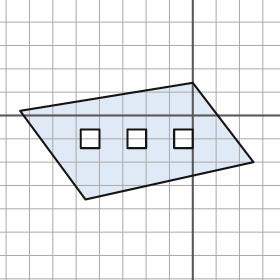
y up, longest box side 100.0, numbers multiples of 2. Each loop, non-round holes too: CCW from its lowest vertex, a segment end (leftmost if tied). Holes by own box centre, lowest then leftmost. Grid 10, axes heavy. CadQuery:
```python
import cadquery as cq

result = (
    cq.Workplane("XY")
    .moveTo(-46.0, -36.0)
    .lineTo(26.0, -20.0)
    .lineTo(0.0, 14.0)
    .lineTo(-74.0, 2.0)
    .close()
    .moveTo(-48.0, -14.0)
    .lineTo(-40.0, -14.0)
    .lineTo(-40.0, -6.0)
    .lineTo(-48.0, -6.0)
    .close()
    .moveTo(-28.0, -14.0)
    .lineTo(-20.0, -14.0)
    .lineTo(-20.0, -6.0)
    .lineTo(-28.0, -6.0)
    .close()
    .moveTo(-8.0, -14.0)
    .lineTo(0.0, -14.0)
    .lineTo(0.0, -6.0)
    .lineTo(-8.0, -6.0)
    .close()
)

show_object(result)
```